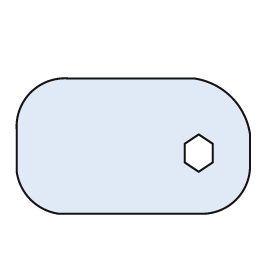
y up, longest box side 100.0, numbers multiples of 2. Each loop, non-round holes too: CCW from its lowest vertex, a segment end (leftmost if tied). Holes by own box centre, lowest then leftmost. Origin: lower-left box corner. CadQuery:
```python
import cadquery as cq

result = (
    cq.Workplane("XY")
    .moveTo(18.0, 0.0)
    .lineTo(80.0, 0.0)
    .threePointArc((94.0, 6.0), (100.0, 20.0))
    .lineTo(100.0, 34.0)
    .threePointArc((92.0, 50.0), (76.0, 58.0))
    .lineTo(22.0, 58.0)
    .threePointArc((6.0, 52.0), (0.0, 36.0))
    .lineTo(0.0, 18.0)
    .threePointArc((6.0, 6.0), (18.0, 0.0))
    .close()
    .moveTo(78.0, 18.0)
    .lineTo(84.0, 22.0)
    .lineTo(84.0, 30.0)
    .lineTo(78.0, 34.0)
    .lineTo(72.0, 30.0)
    .lineTo(72.0, 22.0)
    .close()
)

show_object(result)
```